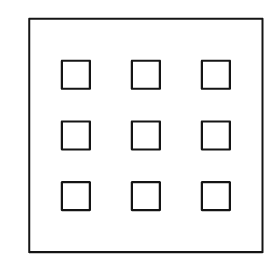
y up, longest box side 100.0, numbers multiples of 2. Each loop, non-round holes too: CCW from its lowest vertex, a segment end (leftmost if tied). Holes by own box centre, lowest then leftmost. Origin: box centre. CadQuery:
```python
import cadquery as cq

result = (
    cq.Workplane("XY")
    .moveTo(-50.0, -50.0)
    .lineTo(50.0, -50.0)
    .lineTo(50.0, 50.0)
    .lineTo(-50.0, 50.0)
    .close()
    .moveTo(-36.0, -32.0)
    .lineTo(-24.0, -32.0)
    .lineTo(-24.0, -20.0)
    .lineTo(-36.0, -20.0)
    .close()
    .moveTo(-6.0, -32.0)
    .lineTo(6.0, -32.0)
    .lineTo(6.0, -20.0)
    .lineTo(-6.0, -20.0)
    .close()
    .moveTo(24.0, -32.0)
    .lineTo(36.0, -32.0)
    .lineTo(36.0, -20.0)
    .lineTo(24.0, -20.0)
    .close()
    .moveTo(-36.0, -6.0)
    .lineTo(-24.0, -6.0)
    .lineTo(-24.0, 6.0)
    .lineTo(-36.0, 6.0)
    .close()
    .moveTo(-6.0, -6.0)
    .lineTo(6.0, -6.0)
    .lineTo(6.0, 6.0)
    .lineTo(-6.0, 6.0)
    .close()
    .moveTo(24.0, -6.0)
    .lineTo(36.0, -6.0)
    .lineTo(36.0, 6.0)
    .lineTo(24.0, 6.0)
    .close()
    .moveTo(-36.0, 20.0)
    .lineTo(-24.0, 20.0)
    .lineTo(-24.0, 32.0)
    .lineTo(-36.0, 32.0)
    .close()
    .moveTo(-6.0, 20.0)
    .lineTo(6.0, 20.0)
    .lineTo(6.0, 32.0)
    .lineTo(-6.0, 32.0)
    .close()
    .moveTo(24.0, 20.0)
    .lineTo(36.0, 20.0)
    .lineTo(36.0, 32.0)
    .lineTo(24.0, 32.0)
    .close()
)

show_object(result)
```